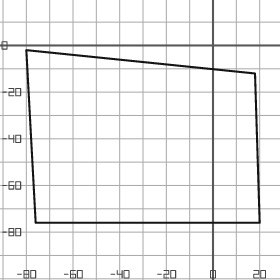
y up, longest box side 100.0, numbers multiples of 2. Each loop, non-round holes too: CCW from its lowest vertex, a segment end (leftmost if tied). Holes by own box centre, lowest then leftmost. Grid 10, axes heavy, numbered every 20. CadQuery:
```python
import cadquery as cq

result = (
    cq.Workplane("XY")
    .moveTo(-76.0, -76.0)
    .lineTo(20.0, -76.0)
    .lineTo(18.0, -12.0)
    .lineTo(-80.0, -2.0)
    .close()
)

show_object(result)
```